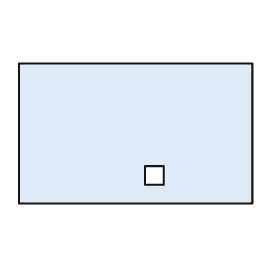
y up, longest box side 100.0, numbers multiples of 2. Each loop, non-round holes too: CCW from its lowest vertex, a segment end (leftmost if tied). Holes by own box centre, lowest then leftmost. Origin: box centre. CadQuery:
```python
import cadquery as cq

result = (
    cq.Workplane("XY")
    .moveTo(-50.0, -30.0)
    .lineTo(50.0, -30.0)
    .lineTo(50.0, 30.0)
    .lineTo(-50.0, 30.0)
    .close()
    .moveTo(4.0, -22.0)
    .lineTo(12.0, -22.0)
    .lineTo(12.0, -14.0)
    .lineTo(4.0, -14.0)
    .close()
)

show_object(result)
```